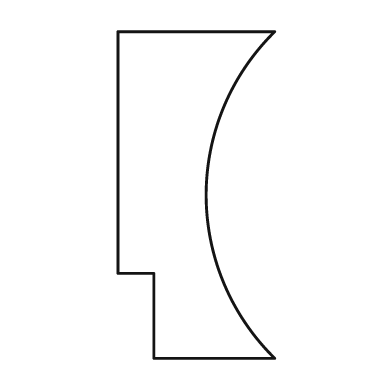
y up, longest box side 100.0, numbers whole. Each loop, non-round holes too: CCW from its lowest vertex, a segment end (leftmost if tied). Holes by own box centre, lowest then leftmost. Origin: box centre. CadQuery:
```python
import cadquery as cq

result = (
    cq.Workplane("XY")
    .moveTo(-13.0, -50.0)
    .lineTo(24.0, -50.0)
    .threePointArc((3.0, 0.0), (24.0, 50.0))
    .lineTo(-24.0, 50.0)
    .lineTo(-24.0, -24.0)
    .lineTo(-13.0, -24.0)
    .close()
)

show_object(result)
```